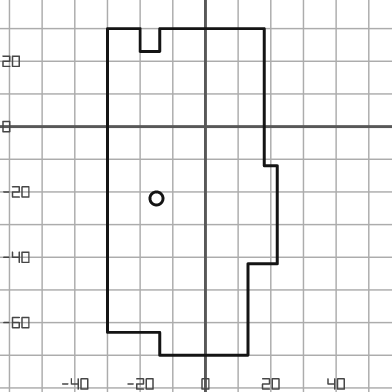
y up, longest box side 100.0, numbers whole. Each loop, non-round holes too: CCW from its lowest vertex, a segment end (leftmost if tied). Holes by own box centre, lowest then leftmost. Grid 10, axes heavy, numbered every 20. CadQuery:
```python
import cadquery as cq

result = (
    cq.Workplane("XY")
    .moveTo(-14.0, -70.0)
    .lineTo(13.0, -70.0)
    .lineTo(13.0, -42.0)
    .lineTo(22.0, -42.0)
    .lineTo(22.0, -12.0)
    .lineTo(18.0, -12.0)
    .lineTo(18.0, 30.0)
    .lineTo(-14.0, 30.0)
    .lineTo(-14.0, 23.0)
    .lineTo(-20.0, 23.0)
    .lineTo(-20.0, 30.0)
    .lineTo(-30.0, 30.0)
    .lineTo(-30.0, -63.0)
    .lineTo(-14.0, -63.0)
    .close()
    .moveTo(-15.0, -22.0)
    .circle(2.0)
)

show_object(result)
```